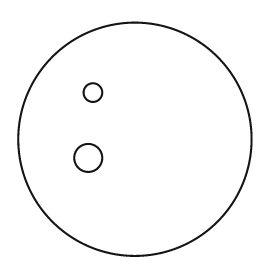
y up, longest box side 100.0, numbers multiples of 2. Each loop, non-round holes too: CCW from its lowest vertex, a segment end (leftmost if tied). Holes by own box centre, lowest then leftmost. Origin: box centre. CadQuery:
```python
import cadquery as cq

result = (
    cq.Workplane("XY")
    .moveTo(0.0, 0.0)
    .circle(50.0)
    .moveTo(-20.0, -8.0)
    .circle(6.0)
    .moveTo(-18.0, 20.0)
    .circle(4.0)
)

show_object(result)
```